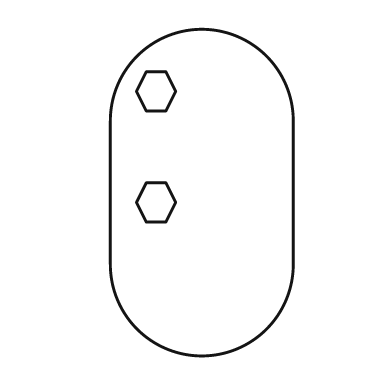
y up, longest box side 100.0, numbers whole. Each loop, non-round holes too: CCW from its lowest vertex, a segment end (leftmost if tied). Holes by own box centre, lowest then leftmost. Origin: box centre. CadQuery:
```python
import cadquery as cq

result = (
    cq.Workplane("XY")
    .moveTo(-28.0, -22.0)
    .threePointArc((0.0, -50.0), (28.0, -22.0))
    .lineTo(28.0, 22.0)
    .threePointArc((0.0, 50.0), (-28.0, 22.0))
    .close()
    .moveTo(-17.0, -9.0)
    .lineTo(-11.0, -9.0)
    .lineTo(-8.0, -3.0)
    .lineTo(-11.0, 3.0)
    .lineTo(-17.0, 3.0)
    .lineTo(-20.0, -3.0)
    .close()
    .moveTo(-17.0, 25.0)
    .lineTo(-11.0, 25.0)
    .lineTo(-8.0, 31.0)
    .lineTo(-11.0, 37.0)
    .lineTo(-17.0, 37.0)
    .lineTo(-20.0, 31.0)
    .close()
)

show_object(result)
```